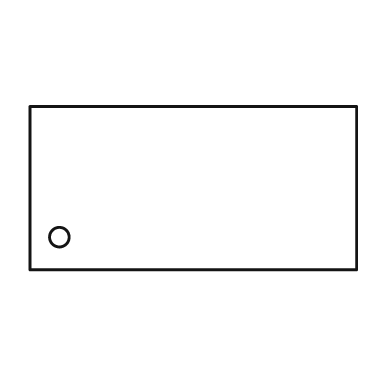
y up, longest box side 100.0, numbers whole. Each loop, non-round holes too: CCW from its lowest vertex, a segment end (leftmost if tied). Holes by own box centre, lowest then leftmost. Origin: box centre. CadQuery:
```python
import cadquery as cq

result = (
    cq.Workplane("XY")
    .moveTo(-50.0, -25.0)
    .lineTo(50.0, -25.0)
    .lineTo(50.0, 25.0)
    .lineTo(-50.0, 25.0)
    .close()
    .moveTo(-41.0, -15.0)
    .circle(3.0)
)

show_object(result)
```